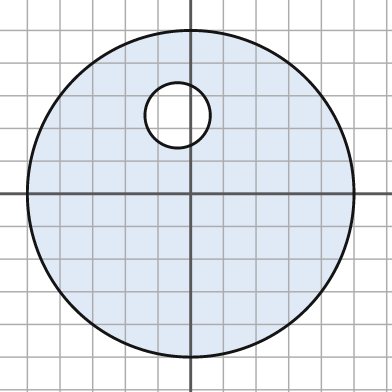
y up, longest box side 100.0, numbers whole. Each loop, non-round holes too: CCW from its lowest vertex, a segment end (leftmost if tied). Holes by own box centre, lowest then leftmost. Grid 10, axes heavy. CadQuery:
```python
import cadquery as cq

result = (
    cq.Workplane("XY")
    .moveTo(0.0, 0.0)
    .circle(50.0)
    .moveTo(-4.0, 24.0)
    .circle(10.0)
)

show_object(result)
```